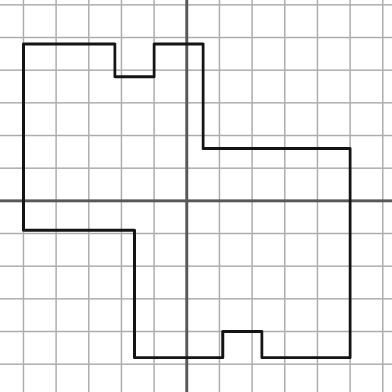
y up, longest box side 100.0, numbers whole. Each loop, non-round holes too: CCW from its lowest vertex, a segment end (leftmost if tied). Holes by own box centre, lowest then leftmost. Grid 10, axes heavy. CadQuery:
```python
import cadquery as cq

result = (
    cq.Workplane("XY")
    .moveTo(-16.0, -48.0)
    .lineTo(11.0, -48.0)
    .lineTo(11.0, -40.0)
    .lineTo(23.0, -40.0)
    .lineTo(23.0, -48.0)
    .lineTo(50.0, -48.0)
    .lineTo(50.0, 16.0)
    .lineTo(5.0, 16.0)
    .lineTo(5.0, 48.0)
    .lineTo(-10.0, 48.0)
    .lineTo(-10.0, 38.0)
    .lineTo(-22.0, 38.0)
    .lineTo(-22.0, 48.0)
    .lineTo(-50.0, 48.0)
    .lineTo(-50.0, -9.0)
    .lineTo(-16.0, -9.0)
    .close()
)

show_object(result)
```